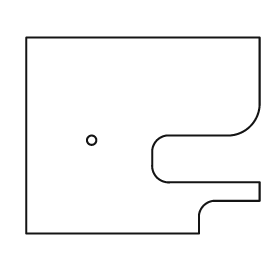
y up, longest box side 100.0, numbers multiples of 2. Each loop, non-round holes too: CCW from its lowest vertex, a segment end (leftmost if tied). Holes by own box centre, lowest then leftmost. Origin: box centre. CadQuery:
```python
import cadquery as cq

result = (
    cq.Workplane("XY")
    .moveTo(-50.0, -42.0)
    .lineTo(24.0, -42.0)
    .lineTo(24.0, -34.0)
    .threePointArc((26.0, -30.0), (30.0, -28.0))
    .lineTo(50.0, -28.0)
    .lineTo(50.0, -20.0)
    .lineTo(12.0, -20.0)
    .threePointArc((6.0, -18.0), (4.0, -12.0))
    .lineTo(4.0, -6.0)
    .threePointArc((6.0, -2.0), (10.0, 0.0))
    .lineTo(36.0, 0.0)
    .threePointArc((46.0, 4.0), (50.0, 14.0))
    .lineTo(50.0, 42.0)
    .lineTo(-50.0, 42.0)
    .close()
    .moveTo(-22.0, -2.0)
    .circle(2.0)
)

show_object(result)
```